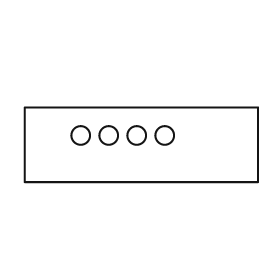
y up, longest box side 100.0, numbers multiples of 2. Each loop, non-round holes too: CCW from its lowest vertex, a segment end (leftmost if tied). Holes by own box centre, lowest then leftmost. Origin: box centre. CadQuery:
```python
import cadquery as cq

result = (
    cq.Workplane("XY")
    .moveTo(-50.0, -16.0)
    .lineTo(50.0, -16.0)
    .lineTo(50.0, 16.0)
    .lineTo(-50.0, 16.0)
    .close()
    .moveTo(-26.0, 4.0)
    .circle(4.0)
    .moveTo(-14.0, 4.0)
    .circle(4.0)
    .moveTo(-2.0, 4.0)
    .circle(4.0)
    .moveTo(10.0, 4.0)
    .circle(4.0)
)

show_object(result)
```